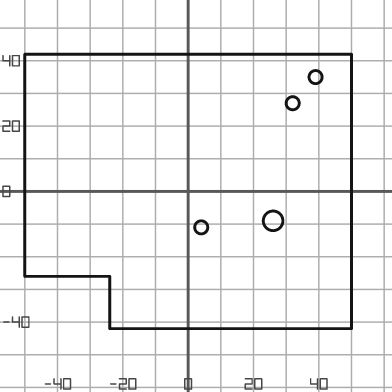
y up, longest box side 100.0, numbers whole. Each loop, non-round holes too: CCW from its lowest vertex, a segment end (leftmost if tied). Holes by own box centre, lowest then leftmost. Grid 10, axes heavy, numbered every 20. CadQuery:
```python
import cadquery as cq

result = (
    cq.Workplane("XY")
    .moveTo(-24.0, -42.0)
    .lineTo(50.0, -42.0)
    .lineTo(50.0, 42.0)
    .lineTo(-50.0, 42.0)
    .lineTo(-50.0, -26.0)
    .lineTo(-24.0, -26.0)
    .close()
    .moveTo(4.0, -11.0)
    .circle(2.0)
    .moveTo(26.0, -9.0)
    .circle(3.0)
    .moveTo(32.0, 27.0)
    .circle(2.0)
    .moveTo(39.0, 35.0)
    .circle(2.0)
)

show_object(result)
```